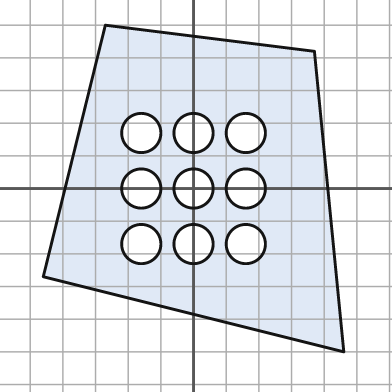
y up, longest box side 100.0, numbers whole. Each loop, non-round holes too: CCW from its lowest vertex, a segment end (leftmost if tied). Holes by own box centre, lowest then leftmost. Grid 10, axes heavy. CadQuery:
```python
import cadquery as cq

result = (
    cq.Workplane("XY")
    .moveTo(46.0, -50.0)
    .lineTo(37.0, 42.0)
    .lineTo(-27.0, 50.0)
    .lineTo(-46.0, -27.0)
    .close()
    .moveTo(-16.0, -17.0)
    .circle(6.0)
    .moveTo(0.0, -17.0)
    .circle(6.0)
    .moveTo(16.0, -17.0)
    .circle(6.0)
    .moveTo(-16.0, 0.0)
    .circle(6.0)
    .moveTo(0.0, 0.0)
    .circle(6.0)
    .moveTo(16.0, 0.0)
    .circle(6.0)
    .moveTo(-16.0, 17.0)
    .circle(6.0)
    .moveTo(0.0, 17.0)
    .circle(6.0)
    .moveTo(16.0, 17.0)
    .circle(6.0)
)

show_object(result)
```